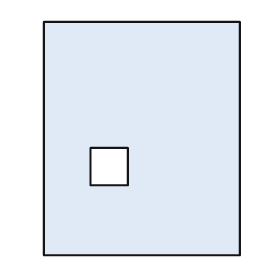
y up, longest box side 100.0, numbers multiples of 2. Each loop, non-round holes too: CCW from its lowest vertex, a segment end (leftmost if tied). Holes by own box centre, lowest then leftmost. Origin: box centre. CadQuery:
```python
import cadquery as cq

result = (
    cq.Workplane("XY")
    .moveTo(-42.0, -50.0)
    .lineTo(42.0, -50.0)
    .lineTo(42.0, 50.0)
    .lineTo(-42.0, 50.0)
    .close()
    .moveTo(-22.0, -20.0)
    .lineTo(-6.0, -20.0)
    .lineTo(-6.0, -4.0)
    .lineTo(-22.0, -4.0)
    .close()
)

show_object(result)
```